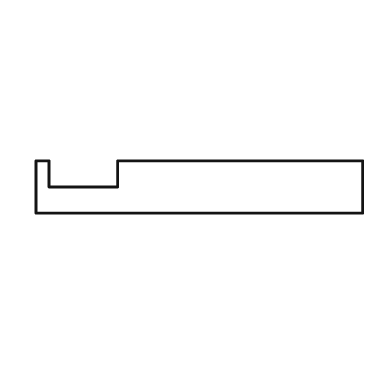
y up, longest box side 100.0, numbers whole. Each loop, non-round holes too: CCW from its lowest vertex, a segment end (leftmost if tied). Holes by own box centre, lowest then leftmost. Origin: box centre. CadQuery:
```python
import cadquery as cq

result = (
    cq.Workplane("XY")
    .moveTo(-50.0, -8.0)
    .lineTo(50.0, -8.0)
    .lineTo(50.0, 8.0)
    .lineTo(-25.0, 8.0)
    .lineTo(-25.0, 0.0)
    .lineTo(-46.0, 0.0)
    .lineTo(-46.0, 8.0)
    .lineTo(-50.0, 8.0)
    .close()
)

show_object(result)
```